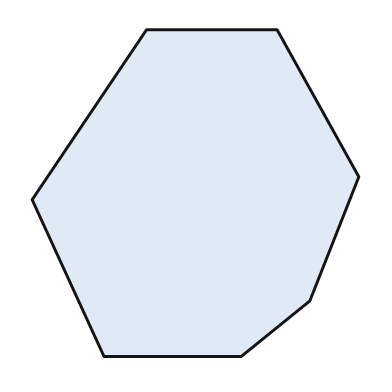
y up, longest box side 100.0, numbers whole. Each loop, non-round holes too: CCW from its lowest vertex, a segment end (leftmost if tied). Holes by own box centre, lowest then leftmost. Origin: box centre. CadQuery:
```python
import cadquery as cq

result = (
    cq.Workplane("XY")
    .moveTo(-28.0, -50.0)
    .lineTo(14.0, -50.0)
    .lineTo(35.0, -33.0)
    .lineTo(50.0, 5.0)
    .lineTo(25.0, 50.0)
    .lineTo(-15.0, 50.0)
    .lineTo(-50.0, -2.0)
    .close()
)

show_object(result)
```